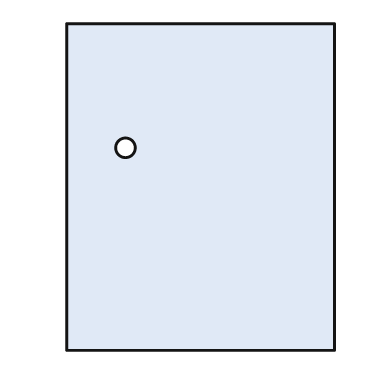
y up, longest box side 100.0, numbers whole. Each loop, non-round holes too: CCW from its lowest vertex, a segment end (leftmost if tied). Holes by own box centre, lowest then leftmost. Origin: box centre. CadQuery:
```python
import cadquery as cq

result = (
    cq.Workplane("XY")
    .moveTo(-41.0, -50.0)
    .lineTo(41.0, -50.0)
    .lineTo(41.0, 50.0)
    .lineTo(-41.0, 50.0)
    .close()
    .moveTo(-23.0, 12.0)
    .circle(3.0)
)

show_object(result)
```